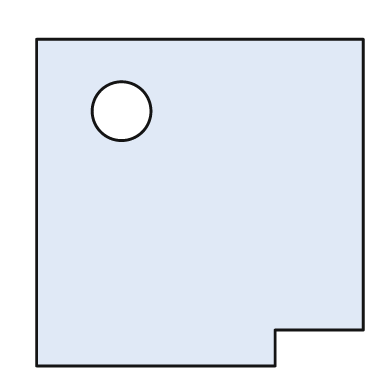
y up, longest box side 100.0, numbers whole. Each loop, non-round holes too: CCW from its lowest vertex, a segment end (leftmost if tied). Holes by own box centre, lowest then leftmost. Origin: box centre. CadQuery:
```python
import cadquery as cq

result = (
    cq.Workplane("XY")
    .moveTo(-50.0, -50.0)
    .lineTo(23.0, -50.0)
    .lineTo(23.0, -39.0)
    .lineTo(50.0, -39.0)
    .lineTo(50.0, 50.0)
    .lineTo(-50.0, 50.0)
    .close()
    .moveTo(-24.0, 28.0)
    .circle(9.0)
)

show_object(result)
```